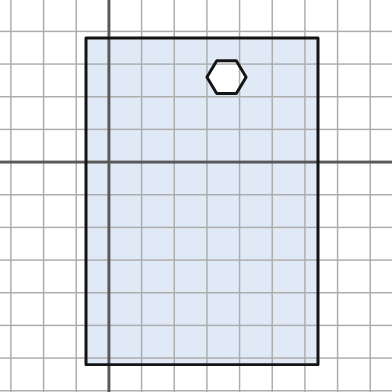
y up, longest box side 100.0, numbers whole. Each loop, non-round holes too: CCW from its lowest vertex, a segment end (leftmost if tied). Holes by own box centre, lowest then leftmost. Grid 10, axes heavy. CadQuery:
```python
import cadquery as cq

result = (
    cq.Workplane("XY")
    .moveTo(-7.0, -62.0)
    .lineTo(64.0, -62.0)
    .lineTo(64.0, 38.0)
    .lineTo(-7.0, 38.0)
    .close()
    .moveTo(33.0, 21.0)
    .lineTo(39.0, 21.0)
    .lineTo(42.0, 26.0)
    .lineTo(39.0, 31.0)
    .lineTo(33.0, 31.0)
    .lineTo(30.0, 26.0)
    .close()
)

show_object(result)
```